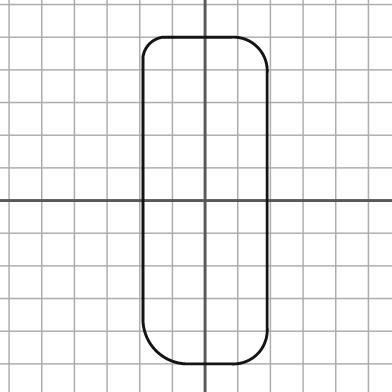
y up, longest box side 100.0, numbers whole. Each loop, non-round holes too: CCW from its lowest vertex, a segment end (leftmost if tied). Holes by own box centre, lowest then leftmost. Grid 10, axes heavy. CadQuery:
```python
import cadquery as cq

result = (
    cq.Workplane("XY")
    .moveTo(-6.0, -50.0)
    .lineTo(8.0, -50.0)
    .threePointArc((16.0, -47.0), (19.0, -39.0))
    .lineTo(19.0, 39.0)
    .threePointArc((16.0, 47.0), (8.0, 50.0))
    .lineTo(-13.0, 50.0)
    .threePointArc((-17.0, 48.0), (-19.0, 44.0))
    .lineTo(-19.0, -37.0)
    .threePointArc((-15.0, -46.0), (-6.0, -50.0))
    .close()
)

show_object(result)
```